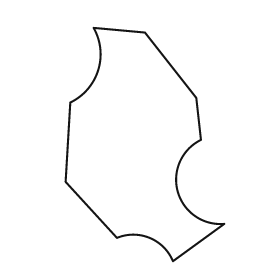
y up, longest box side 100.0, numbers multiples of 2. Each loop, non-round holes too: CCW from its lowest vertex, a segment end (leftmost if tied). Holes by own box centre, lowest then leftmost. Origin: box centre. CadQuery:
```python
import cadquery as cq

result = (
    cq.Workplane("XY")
    .moveTo(12.0, -50.0)
    .lineTo(34.0, -34.0)
    .threePointArc((14.0, -20.0), (24.0, 2.0))
    .lineTo(22.0, 20.0)
    .lineTo(0.0, 48.0)
    .lineTo(-22.0, 50.0)
    .threePointArc((-20.0, 32.0), (-32.0, 18.0))
    .lineTo(-34.0, -16.0)
    .lineTo(-12.0, -40.0)
    .threePointArc((2.0, -40.0), (12.0, -50.0))
    .close()
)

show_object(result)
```